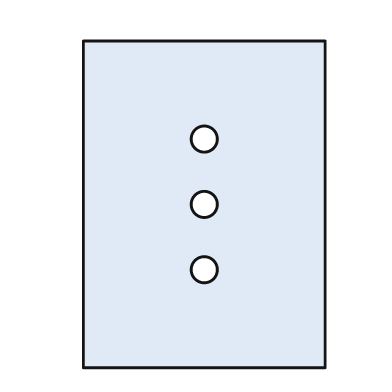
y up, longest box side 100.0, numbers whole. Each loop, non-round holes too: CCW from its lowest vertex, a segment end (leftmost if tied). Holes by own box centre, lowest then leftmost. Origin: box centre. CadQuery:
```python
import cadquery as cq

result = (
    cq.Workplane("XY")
    .moveTo(-37.0, -50.0)
    .lineTo(37.0, -50.0)
    .lineTo(37.0, 50.0)
    .lineTo(-37.0, 50.0)
    .close()
    .moveTo(0.0, -20.0)
    .circle(4.0)
    .moveTo(0.0, 0.0)
    .circle(4.0)
    .moveTo(0.0, 20.0)
    .circle(4.0)
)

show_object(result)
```